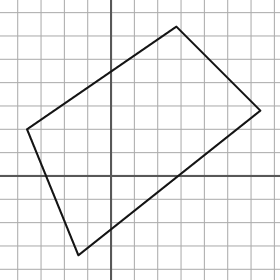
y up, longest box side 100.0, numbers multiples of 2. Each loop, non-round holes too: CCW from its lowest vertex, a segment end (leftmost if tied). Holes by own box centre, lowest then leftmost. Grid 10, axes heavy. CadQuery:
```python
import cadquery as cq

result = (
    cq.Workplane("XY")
    .moveTo(-14.0, -34.0)
    .lineTo(64.0, 28.0)
    .lineTo(28.0, 64.0)
    .lineTo(-36.0, 20.0)
    .close()
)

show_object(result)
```